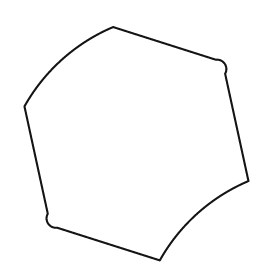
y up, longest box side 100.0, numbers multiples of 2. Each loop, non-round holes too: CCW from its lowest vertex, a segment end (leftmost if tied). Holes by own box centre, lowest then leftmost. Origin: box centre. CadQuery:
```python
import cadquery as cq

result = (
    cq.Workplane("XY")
    .moveTo(10.0, -50.0)
    .threePointArc((26.0, -30.0), (48.0, -16.0))
    .lineTo(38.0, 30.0)
    .threePointArc((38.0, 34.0), (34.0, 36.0))
    .lineTo(-10.0, 50.0)
    .threePointArc((-32.0, 36.0), (-48.0, 16.0))
    .lineTo(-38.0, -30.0)
    .threePointArc((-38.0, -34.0), (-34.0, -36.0))
    .close()
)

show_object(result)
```